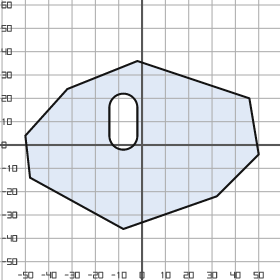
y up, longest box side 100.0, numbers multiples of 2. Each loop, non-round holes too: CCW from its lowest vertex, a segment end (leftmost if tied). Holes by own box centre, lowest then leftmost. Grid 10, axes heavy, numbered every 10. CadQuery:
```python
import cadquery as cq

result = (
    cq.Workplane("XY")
    .moveTo(-8.0, -36.0)
    .lineTo(32.0, -22.0)
    .lineTo(50.0, -4.0)
    .lineTo(46.0, 20.0)
    .lineTo(-2.0, 36.0)
    .lineTo(-32.0, 24.0)
    .lineTo(-50.0, 4.0)
    .lineTo(-48.0, -14.0)
    .close()
    .moveTo(-14.0, 4.0)
    .threePointArc((-8.0, -2.0), (-2.0, 4.0))
    .lineTo(-2.0, 16.0)
    .threePointArc((-8.0, 22.0), (-14.0, 16.0))
    .close()
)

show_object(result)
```